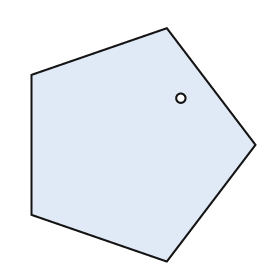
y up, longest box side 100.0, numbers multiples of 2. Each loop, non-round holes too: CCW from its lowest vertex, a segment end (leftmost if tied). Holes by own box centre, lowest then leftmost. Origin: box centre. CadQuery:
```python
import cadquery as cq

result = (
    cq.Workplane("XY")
    .moveTo(10.0, -50.0)
    .lineTo(48.0, 0.0)
    .lineTo(10.0, 50.0)
    .lineTo(-48.0, 30.0)
    .lineTo(-48.0, -30.0)
    .close()
    .moveTo(16.0, 20.0)
    .circle(2.0)
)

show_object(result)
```